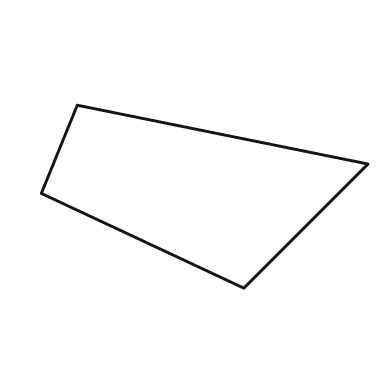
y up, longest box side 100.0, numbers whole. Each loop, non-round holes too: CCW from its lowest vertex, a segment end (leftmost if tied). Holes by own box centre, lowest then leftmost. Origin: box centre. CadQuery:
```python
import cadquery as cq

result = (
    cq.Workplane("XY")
    .moveTo(12.0, -28.0)
    .lineTo(50.0, 10.0)
    .lineTo(-39.0, 28.0)
    .lineTo(-50.0, 1.0)
    .close()
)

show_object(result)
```